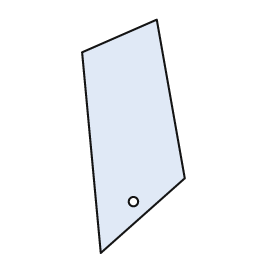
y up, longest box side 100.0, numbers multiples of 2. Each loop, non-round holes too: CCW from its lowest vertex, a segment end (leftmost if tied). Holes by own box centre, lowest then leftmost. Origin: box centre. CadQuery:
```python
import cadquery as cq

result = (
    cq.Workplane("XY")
    .moveTo(-14.0, -50.0)
    .lineTo(22.0, -18.0)
    .lineTo(10.0, 50.0)
    .lineTo(-22.0, 36.0)
    .close()
    .moveTo(0.0, -28.0)
    .circle(2.0)
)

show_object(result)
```